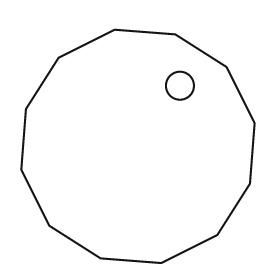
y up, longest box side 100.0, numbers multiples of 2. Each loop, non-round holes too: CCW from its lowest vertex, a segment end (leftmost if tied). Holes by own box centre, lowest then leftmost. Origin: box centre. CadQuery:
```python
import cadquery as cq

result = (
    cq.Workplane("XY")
    .moveTo(10.0, -50.0)
    .lineTo(34.0, -38.0)
    .lineTo(48.0, -16.0)
    .lineTo(50.0, 10.0)
    .lineTo(38.0, 34.0)
    .lineTo(16.0, 48.0)
    .lineTo(-10.0, 50.0)
    .lineTo(-34.0, 38.0)
    .lineTo(-48.0, 16.0)
    .lineTo(-50.0, -10.0)
    .lineTo(-38.0, -34.0)
    .lineTo(-16.0, -48.0)
    .close()
    .moveTo(18.0, 26.0)
    .circle(6.0)
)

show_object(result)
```